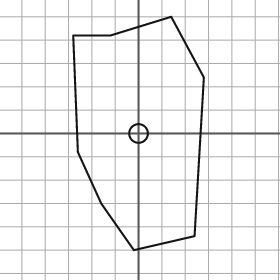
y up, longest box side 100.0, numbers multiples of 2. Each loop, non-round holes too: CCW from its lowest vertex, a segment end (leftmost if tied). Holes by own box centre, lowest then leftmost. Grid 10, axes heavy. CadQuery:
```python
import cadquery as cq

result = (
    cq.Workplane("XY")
    .moveTo(-2.0, -50.0)
    .lineTo(24.0, -44.0)
    .lineTo(28.0, 24.0)
    .lineTo(14.0, 50.0)
    .lineTo(-12.0, 42.0)
    .lineTo(-28.0, 42.0)
    .lineTo(-26.0, -8.0)
    .lineTo(-16.0, -30.0)
    .close()
    .moveTo(0.0, 0.0)
    .circle(4.0)
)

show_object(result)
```